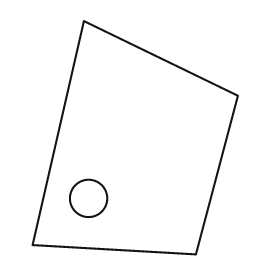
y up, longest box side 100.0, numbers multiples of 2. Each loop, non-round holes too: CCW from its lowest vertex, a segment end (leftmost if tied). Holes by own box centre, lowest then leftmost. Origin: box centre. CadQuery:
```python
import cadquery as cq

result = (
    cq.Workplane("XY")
    .moveTo(26.0, -50.0)
    .lineTo(44.0, 18.0)
    .lineTo(-22.0, 50.0)
    .lineTo(-44.0, -46.0)
    .close()
    .moveTo(-20.0, -26.0)
    .circle(8.0)
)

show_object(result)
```